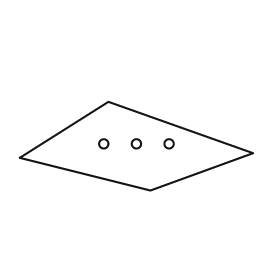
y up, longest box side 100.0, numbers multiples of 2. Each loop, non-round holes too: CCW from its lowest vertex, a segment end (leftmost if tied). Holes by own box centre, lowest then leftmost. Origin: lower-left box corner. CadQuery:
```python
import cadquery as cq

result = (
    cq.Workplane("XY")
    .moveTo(56.0, 0.0)
    .lineTo(100.0, 16.0)
    .lineTo(38.0, 38.0)
    .lineTo(0.0, 14.0)
    .close()
    .moveTo(36.0, 20.0)
    .circle(2.0)
    .moveTo(50.0, 20.0)
    .circle(2.0)
    .moveTo(64.0, 20.0)
    .circle(2.0)
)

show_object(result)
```